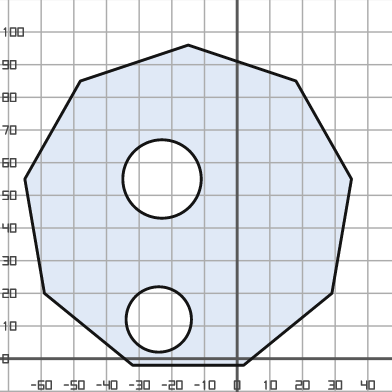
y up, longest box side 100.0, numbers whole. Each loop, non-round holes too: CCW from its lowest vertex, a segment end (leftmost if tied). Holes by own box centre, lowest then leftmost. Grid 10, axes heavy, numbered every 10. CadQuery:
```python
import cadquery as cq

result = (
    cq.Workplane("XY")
    .moveTo(-32.0, -2.0)
    .lineTo(2.0, -2.0)
    .lineTo(29.0, 20.0)
    .lineTo(35.0, 55.0)
    .lineTo(18.0, 85.0)
    .lineTo(-15.0, 96.0)
    .lineTo(-48.0, 85.0)
    .lineTo(-65.0, 55.0)
    .lineTo(-59.0, 20.0)
    .close()
    .moveTo(-24.0, 12.0)
    .circle(10.0)
    .moveTo(-23.0, 55.0)
    .circle(12.0)
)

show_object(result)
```